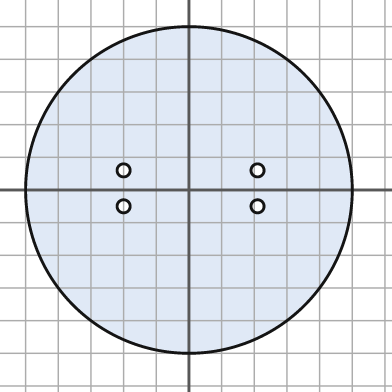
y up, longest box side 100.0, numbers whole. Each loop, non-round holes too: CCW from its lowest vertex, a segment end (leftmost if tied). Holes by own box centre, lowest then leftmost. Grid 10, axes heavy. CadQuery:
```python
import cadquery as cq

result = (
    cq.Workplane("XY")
    .moveTo(0.0, 0.0)
    .circle(50.0)
    .moveTo(-20.0, -5.0)
    .circle(2.0)
    .moveTo(21.0, -5.0)
    .circle(2.0)
    .moveTo(-20.0, 6.0)
    .circle(2.0)
    .moveTo(21.0, 6.0)
    .circle(2.0)
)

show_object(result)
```